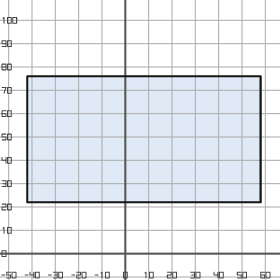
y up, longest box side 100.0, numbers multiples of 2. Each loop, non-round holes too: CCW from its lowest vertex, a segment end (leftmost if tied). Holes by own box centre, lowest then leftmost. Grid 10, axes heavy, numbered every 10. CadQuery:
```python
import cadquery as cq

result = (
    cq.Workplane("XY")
    .moveTo(-42.0, 22.0)
    .lineTo(58.0, 22.0)
    .lineTo(58.0, 76.0)
    .lineTo(-42.0, 76.0)
    .close()
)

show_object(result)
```